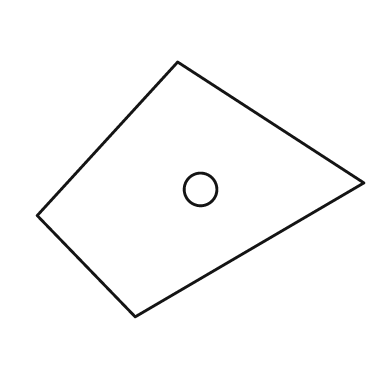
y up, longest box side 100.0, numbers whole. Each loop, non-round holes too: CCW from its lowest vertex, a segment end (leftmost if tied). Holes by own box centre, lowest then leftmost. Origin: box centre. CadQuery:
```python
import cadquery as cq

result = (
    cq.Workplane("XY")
    .moveTo(-20.0, -39.0)
    .lineTo(50.0, 2.0)
    .lineTo(-7.0, 39.0)
    .lineTo(-50.0, -8.0)
    .close()
    .moveTo(0.0, 0.0)
    .circle(5.0)
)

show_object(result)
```